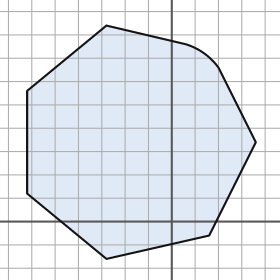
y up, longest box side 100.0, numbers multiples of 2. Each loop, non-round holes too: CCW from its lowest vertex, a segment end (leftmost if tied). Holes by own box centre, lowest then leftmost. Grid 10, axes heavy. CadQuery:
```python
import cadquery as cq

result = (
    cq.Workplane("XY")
    .moveTo(-28.0, -16.0)
    .lineTo(16.0, -6.0)
    .lineTo(36.0, 34.0)
    .lineTo(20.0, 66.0)
    .threePointArc((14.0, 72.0), (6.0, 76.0))
    .lineTo(-28.0, 84.0)
    .lineTo(-62.0, 56.0)
    .lineTo(-62.0, 12.0)
    .close()
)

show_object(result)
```